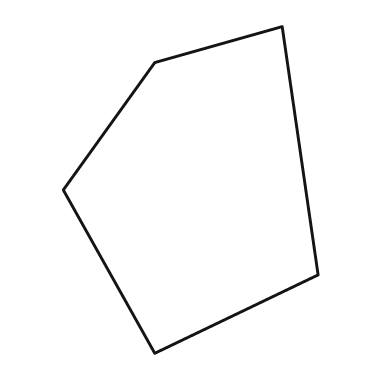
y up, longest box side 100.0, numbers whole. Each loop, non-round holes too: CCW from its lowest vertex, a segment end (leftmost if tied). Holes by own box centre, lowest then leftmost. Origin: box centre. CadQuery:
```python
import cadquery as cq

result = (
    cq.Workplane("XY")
    .moveTo(-11.0, -50.0)
    .lineTo(39.0, -26.0)
    .lineTo(28.0, 50.0)
    .lineTo(-11.0, 39.0)
    .lineTo(-39.0, 0.0)
    .close()
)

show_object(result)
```